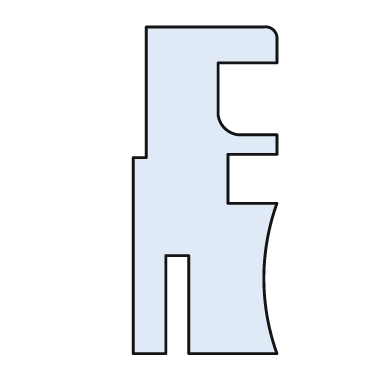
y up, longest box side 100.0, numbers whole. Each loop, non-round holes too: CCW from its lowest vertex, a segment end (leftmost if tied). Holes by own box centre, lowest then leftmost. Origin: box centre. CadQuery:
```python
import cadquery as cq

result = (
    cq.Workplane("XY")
    .moveTo(-22.0, -50.0)
    .lineTo(-12.0, -50.0)
    .lineTo(-12.0, -20.0)
    .lineTo(-5.0, -20.0)
    .lineTo(-5.0, -50.0)
    .lineTo(22.0, -50.0)
    .threePointArc((18.0, -27.0), (22.0, -4.0))
    .lineTo(7.0, -4.0)
    .lineTo(7.0, 11.0)
    .lineTo(22.0, 11.0)
    .lineTo(22.0, 17.0)
    .lineTo(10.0, 17.0)
    .threePointArc((6.0, 19.0), (4.0, 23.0))
    .lineTo(4.0, 39.0)
    .lineTo(22.0, 39.0)
    .lineTo(22.0, 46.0)
    .threePointArc((21.0, 49.0), (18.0, 50.0))
    .lineTo(-18.0, 50.0)
    .lineTo(-18.0, 10.0)
    .lineTo(-22.0, 10.0)
    .close()
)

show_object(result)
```